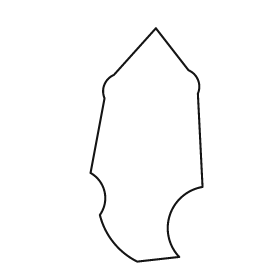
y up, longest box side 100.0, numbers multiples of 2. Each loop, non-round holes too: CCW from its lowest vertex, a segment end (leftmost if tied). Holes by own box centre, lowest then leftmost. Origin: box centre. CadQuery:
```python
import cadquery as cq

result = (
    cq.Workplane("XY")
    .moveTo(-4.0, -50.0)
    .lineTo(14.0, -48.0)
    .threePointArc((10.0, -30.0), (24.0, -18.0))
    .lineTo(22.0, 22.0)
    .threePointArc((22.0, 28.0), (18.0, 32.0))
    .lineTo(4.0, 50.0)
    .lineTo(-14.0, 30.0)
    .threePointArc((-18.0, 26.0), (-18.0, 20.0))
    .lineTo(-24.0, -12.0)
    .threePointArc((-18.0, -20.0), (-20.0, -30.0))
    .threePointArc((-14.0, -42.0), (-4.0, -50.0))
    .close()
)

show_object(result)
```